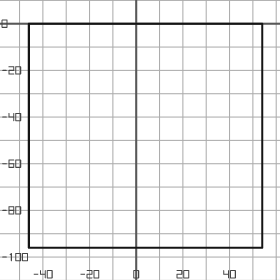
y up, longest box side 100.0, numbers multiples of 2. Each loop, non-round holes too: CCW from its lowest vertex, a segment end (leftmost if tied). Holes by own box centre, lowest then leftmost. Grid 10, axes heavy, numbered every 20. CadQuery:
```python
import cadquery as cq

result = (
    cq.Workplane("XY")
    .moveTo(-46.0, -96.0)
    .lineTo(54.0, -96.0)
    .lineTo(54.0, 0.0)
    .lineTo(-46.0, 0.0)
    .close()
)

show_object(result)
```